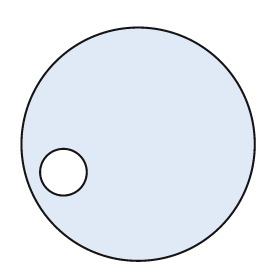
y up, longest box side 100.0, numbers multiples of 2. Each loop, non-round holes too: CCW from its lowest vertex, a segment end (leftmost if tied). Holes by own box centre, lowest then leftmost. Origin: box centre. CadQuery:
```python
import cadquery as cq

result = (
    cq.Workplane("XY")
    .moveTo(0.0, 0.0)
    .circle(50.0)
    .moveTo(-32.0, -12.0)
    .circle(10.0)
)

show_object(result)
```